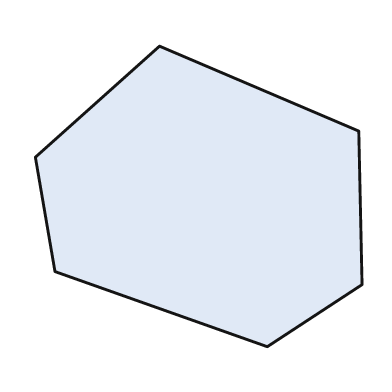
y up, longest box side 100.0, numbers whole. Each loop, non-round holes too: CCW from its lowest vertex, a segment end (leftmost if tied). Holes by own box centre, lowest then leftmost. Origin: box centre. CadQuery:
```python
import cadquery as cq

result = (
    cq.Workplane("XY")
    .moveTo(21.0, -46.0)
    .lineTo(50.0, -27.0)
    .lineTo(49.0, 20.0)
    .lineTo(-12.0, 46.0)
    .lineTo(-50.0, 12.0)
    .lineTo(-44.0, -23.0)
    .close()
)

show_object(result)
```